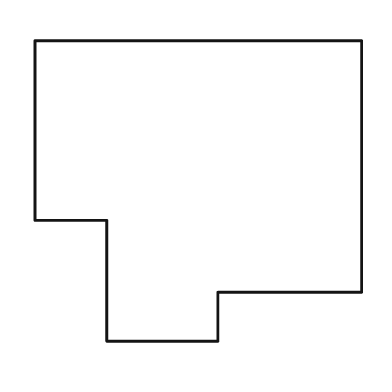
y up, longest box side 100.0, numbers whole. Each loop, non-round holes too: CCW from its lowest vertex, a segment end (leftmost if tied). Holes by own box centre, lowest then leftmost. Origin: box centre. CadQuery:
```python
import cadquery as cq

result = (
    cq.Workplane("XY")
    .moveTo(-28.0, -46.0)
    .lineTo(6.0, -46.0)
    .lineTo(6.0, -31.0)
    .lineTo(50.0, -31.0)
    .lineTo(50.0, 46.0)
    .lineTo(-50.0, 46.0)
    .lineTo(-50.0, -9.0)
    .lineTo(-28.0, -9.0)
    .close()
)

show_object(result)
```